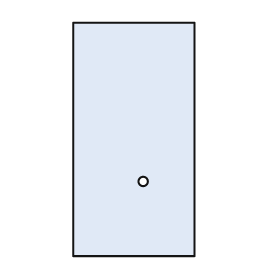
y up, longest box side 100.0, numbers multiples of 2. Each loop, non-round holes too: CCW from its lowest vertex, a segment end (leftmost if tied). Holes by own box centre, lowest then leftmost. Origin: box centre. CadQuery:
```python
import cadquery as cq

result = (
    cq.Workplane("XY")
    .moveTo(-26.0, -50.0)
    .lineTo(26.0, -50.0)
    .lineTo(26.0, 50.0)
    .lineTo(-26.0, 50.0)
    .close()
    .moveTo(4.0, -18.0)
    .circle(2.0)
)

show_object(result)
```